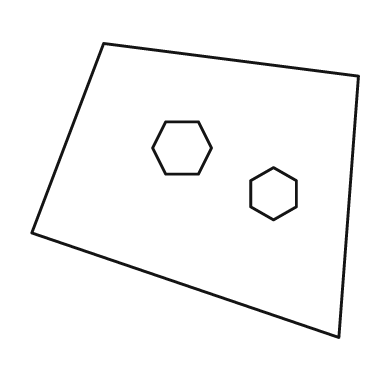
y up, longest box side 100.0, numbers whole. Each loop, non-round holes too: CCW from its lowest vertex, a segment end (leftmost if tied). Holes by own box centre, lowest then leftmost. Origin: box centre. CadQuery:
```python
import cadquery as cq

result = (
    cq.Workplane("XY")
    .moveTo(44.0, -45.0)
    .lineTo(50.0, 35.0)
    .lineTo(-28.0, 45.0)
    .lineTo(-50.0, -13.0)
    .close()
    .moveTo(24.0, -9.0)
    .lineTo(31.0, -5.0)
    .lineTo(31.0, 3.0)
    .lineTo(24.0, 7.0)
    .lineTo(17.0, 3.0)
    .lineTo(17.0, -5.0)
    .close()
    .moveTo(-9.0, 5.0)
    .lineTo(1.0, 5.0)
    .lineTo(5.0, 13.0)
    .lineTo(1.0, 21.0)
    .lineTo(-9.0, 21.0)
    .lineTo(-13.0, 13.0)
    .close()
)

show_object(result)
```